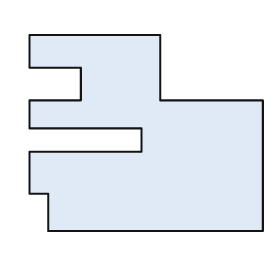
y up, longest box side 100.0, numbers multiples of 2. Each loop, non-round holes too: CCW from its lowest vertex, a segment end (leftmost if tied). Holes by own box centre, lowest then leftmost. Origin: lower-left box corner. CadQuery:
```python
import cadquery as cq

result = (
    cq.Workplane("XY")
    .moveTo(8.0, 0.0)
    .lineTo(100.0, 0.0)
    .lineTo(100.0, 56.0)
    .lineTo(56.0, 56.0)
    .lineTo(56.0, 84.0)
    .lineTo(0.0, 84.0)
    .lineTo(0.0, 70.0)
    .lineTo(22.0, 70.0)
    .lineTo(22.0, 56.0)
    .lineTo(0.0, 56.0)
    .lineTo(0.0, 44.0)
    .lineTo(48.0, 44.0)
    .lineTo(48.0, 34.0)
    .lineTo(0.0, 34.0)
    .lineTo(0.0, 16.0)
    .lineTo(8.0, 16.0)
    .close()
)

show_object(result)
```